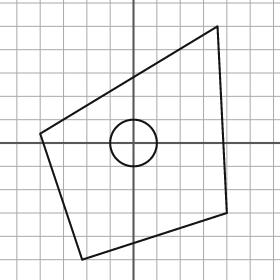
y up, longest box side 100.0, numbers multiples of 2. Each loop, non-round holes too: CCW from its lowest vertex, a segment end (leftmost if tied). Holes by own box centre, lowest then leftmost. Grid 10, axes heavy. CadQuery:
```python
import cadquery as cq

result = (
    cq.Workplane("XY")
    .moveTo(-22.0, -50.0)
    .lineTo(40.0, -30.0)
    .lineTo(36.0, 50.0)
    .lineTo(-40.0, 4.0)
    .close()
    .moveTo(0.0, 0.0)
    .circle(10.0)
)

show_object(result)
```